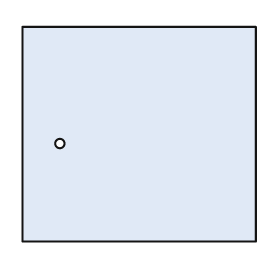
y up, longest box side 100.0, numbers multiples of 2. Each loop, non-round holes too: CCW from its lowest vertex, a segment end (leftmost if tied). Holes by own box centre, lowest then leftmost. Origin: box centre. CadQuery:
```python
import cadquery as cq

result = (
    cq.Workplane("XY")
    .moveTo(-50.0, -46.0)
    .lineTo(50.0, -46.0)
    .lineTo(50.0, 46.0)
    .lineTo(-50.0, 46.0)
    .close()
    .moveTo(-34.0, -4.0)
    .circle(2.0)
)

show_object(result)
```